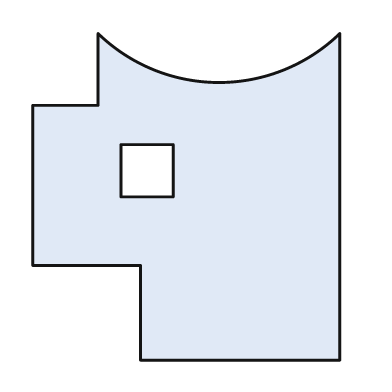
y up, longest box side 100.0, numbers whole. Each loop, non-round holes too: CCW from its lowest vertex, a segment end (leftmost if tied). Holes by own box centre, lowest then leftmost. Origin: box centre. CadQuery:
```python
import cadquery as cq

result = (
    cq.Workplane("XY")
    .moveTo(-14.0, -50.0)
    .lineTo(47.0, -50.0)
    .lineTo(47.0, 50.0)
    .threePointArc((10.0, 35.0), (-27.0, 50.0))
    .lineTo(-27.0, 28.0)
    .lineTo(-47.0, 28.0)
    .lineTo(-47.0, -21.0)
    .lineTo(-14.0, -21.0)
    .close()
    .moveTo(-20.0, 0.0)
    .lineTo(-4.0, 0.0)
    .lineTo(-4.0, 16.0)
    .lineTo(-20.0, 16.0)
    .close()
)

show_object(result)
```